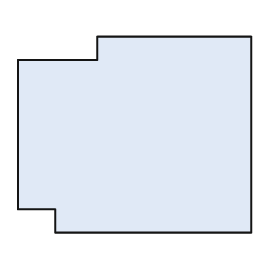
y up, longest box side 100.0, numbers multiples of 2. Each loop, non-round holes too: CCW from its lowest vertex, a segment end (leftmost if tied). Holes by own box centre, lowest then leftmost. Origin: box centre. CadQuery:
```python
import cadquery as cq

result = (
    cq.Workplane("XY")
    .moveTo(-34.0, -42.0)
    .lineTo(50.0, -42.0)
    .lineTo(50.0, 42.0)
    .lineTo(-16.0, 42.0)
    .lineTo(-16.0, 32.0)
    .lineTo(-50.0, 32.0)
    .lineTo(-50.0, -32.0)
    .lineTo(-34.0, -32.0)
    .close()
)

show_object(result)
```